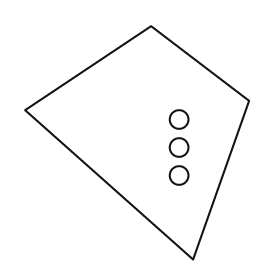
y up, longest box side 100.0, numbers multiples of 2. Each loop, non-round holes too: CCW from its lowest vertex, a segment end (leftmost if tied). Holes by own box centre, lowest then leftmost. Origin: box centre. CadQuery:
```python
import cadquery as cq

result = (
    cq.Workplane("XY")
    .moveTo(24.0, -50.0)
    .lineTo(48.0, 18.0)
    .lineTo(6.0, 50.0)
    .lineTo(-48.0, 14.0)
    .close()
    .moveTo(18.0, -14.0)
    .circle(4.0)
    .moveTo(18.0, -2.0)
    .circle(4.0)
    .moveTo(18.0, 10.0)
    .circle(4.0)
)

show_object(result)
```